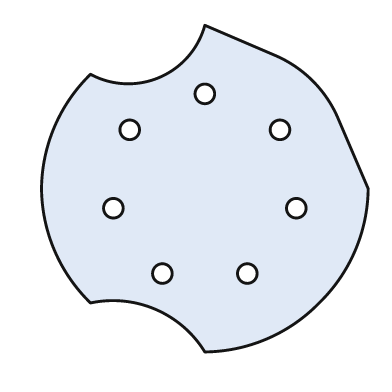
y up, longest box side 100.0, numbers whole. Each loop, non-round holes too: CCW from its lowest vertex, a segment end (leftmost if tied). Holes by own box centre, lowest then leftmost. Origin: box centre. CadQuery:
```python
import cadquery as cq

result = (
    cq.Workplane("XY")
    .moveTo(0.0, -50.0)
    .threePointArc((19.0, -46.0), (35.0, -35.0))
    .threePointArc((46.0, -19.0), (50.0, 0.0))
    .lineTo(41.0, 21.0)
    .threePointArc((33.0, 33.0), (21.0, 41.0))
    .lineTo(0.0, 50.0)
    .threePointArc((-14.0, 34.0), (-35.0, 35.0))
    .threePointArc((-46.0, 19.0), (-50.0, 0.0))
    .threePointArc((-46.0, -19.0), (-35.0, -35.0))
    .threePointArc((-15.0, -37.0), (0.0, -50.0))
    .close()
    .moveTo(-13.0, -26.0)
    .circle(3.0)
    .moveTo(13.0, -26.0)
    .circle(3.0)
    .moveTo(-28.0, -6.0)
    .circle(3.0)
    .moveTo(28.0, -6.0)
    .circle(3.0)
    .moveTo(-23.0, 18.0)
    .circle(3.0)
    .moveTo(23.0, 18.0)
    .circle(3.0)
    .moveTo(0.0, 29.0)
    .circle(3.0)
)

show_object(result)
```